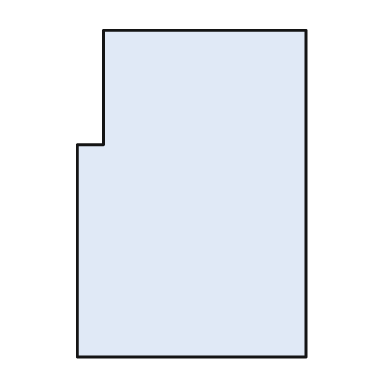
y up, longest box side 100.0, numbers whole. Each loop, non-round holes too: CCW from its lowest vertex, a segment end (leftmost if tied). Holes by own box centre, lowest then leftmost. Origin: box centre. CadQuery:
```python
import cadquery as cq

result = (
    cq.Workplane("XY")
    .moveTo(-35.0, -50.0)
    .lineTo(35.0, -50.0)
    .lineTo(35.0, 50.0)
    .lineTo(-27.0, 50.0)
    .lineTo(-27.0, 15.0)
    .lineTo(-35.0, 15.0)
    .close()
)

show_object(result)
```